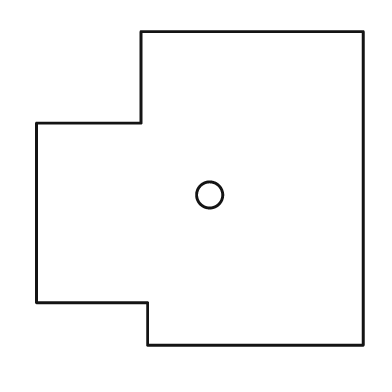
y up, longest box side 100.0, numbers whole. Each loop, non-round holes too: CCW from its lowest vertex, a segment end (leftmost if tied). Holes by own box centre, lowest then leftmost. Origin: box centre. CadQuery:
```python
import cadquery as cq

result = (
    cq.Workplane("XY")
    .moveTo(-16.0, -48.0)
    .lineTo(50.0, -48.0)
    .lineTo(50.0, 48.0)
    .lineTo(-18.0, 48.0)
    .lineTo(-18.0, 20.0)
    .lineTo(-50.0, 20.0)
    .lineTo(-50.0, -35.0)
    .lineTo(-16.0, -35.0)
    .close()
    .moveTo(3.0, -2.0)
    .circle(4.0)
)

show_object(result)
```